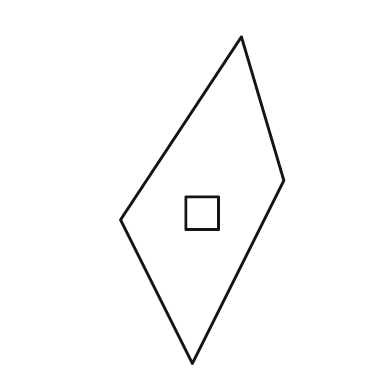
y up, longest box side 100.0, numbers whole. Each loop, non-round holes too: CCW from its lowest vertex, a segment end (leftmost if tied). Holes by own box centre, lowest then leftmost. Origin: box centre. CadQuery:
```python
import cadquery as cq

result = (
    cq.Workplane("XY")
    .moveTo(-3.0, -50.0)
    .lineTo(25.0, 6.0)
    .lineTo(12.0, 50.0)
    .lineTo(-25.0, -6.0)
    .close()
    .moveTo(-5.0, -9.0)
    .lineTo(5.0, -9.0)
    .lineTo(5.0, 1.0)
    .lineTo(-5.0, 1.0)
    .close()
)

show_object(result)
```